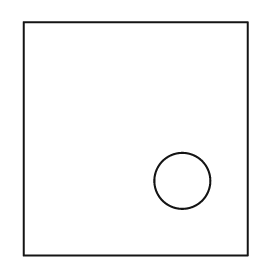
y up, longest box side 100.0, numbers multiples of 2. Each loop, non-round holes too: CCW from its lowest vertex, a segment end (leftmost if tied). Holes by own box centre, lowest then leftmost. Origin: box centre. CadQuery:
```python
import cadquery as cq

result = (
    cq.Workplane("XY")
    .moveTo(-48.0, -50.0)
    .lineTo(48.0, -50.0)
    .lineTo(48.0, 50.0)
    .lineTo(-48.0, 50.0)
    .close()
    .moveTo(20.0, -18.0)
    .circle(12.0)
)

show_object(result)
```